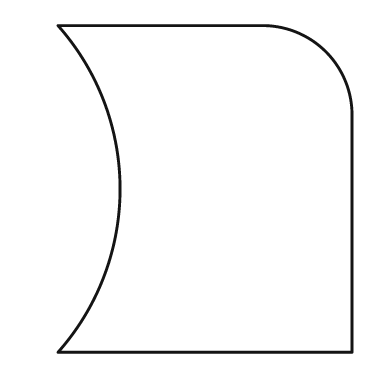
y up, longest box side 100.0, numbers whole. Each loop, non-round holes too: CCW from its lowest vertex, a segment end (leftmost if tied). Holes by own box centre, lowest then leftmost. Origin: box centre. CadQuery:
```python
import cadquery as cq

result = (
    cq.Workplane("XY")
    .moveTo(-45.0, -50.0)
    .lineTo(45.0, -50.0)
    .lineTo(45.0, 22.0)
    .threePointArc((37.0, 42.0), (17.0, 50.0))
    .lineTo(-45.0, 50.0)
    .threePointArc((-26.0, 0.0), (-45.0, -50.0))
    .close()
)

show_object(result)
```